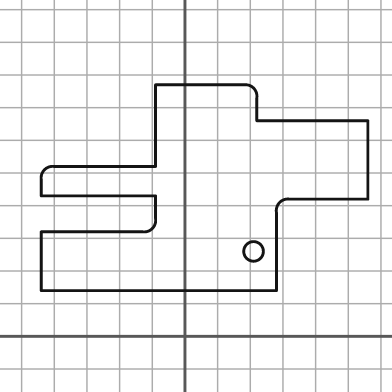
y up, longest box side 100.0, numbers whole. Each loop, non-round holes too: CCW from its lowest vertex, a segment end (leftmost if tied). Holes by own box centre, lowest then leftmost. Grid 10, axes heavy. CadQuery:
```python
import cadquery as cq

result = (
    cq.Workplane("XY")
    .moveTo(-44.0, 14.0)
    .lineTo(28.0, 14.0)
    .lineTo(28.0, 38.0)
    .threePointArc((29.0, 41.0), (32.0, 42.0))
    .lineTo(56.0, 42.0)
    .lineTo(56.0, 66.0)
    .lineTo(22.0, 66.0)
    .lineTo(22.0, 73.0)
    .threePointArc((21.0, 76.0), (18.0, 77.0))
    .lineTo(-9.0, 77.0)
    .lineTo(-9.0, 52.0)
    .lineTo(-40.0, 52.0)
    .threePointArc((-43.0, 51.0), (-44.0, 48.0))
    .lineTo(-44.0, 43.0)
    .lineTo(-9.0, 43.0)
    .lineTo(-9.0, 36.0)
    .threePointArc((-10.0, 33.0), (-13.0, 32.0))
    .lineTo(-44.0, 32.0)
    .close()
    .moveTo(21.0, 26.0)
    .circle(3.0)
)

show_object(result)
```